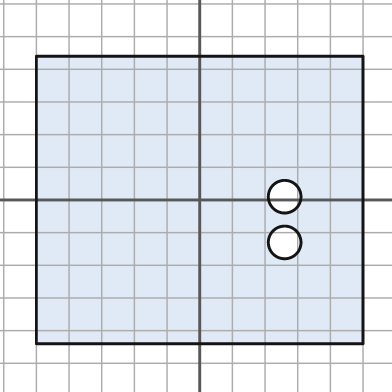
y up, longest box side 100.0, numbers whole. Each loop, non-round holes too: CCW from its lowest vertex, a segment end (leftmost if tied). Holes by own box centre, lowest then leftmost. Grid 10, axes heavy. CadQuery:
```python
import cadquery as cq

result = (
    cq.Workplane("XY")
    .moveTo(-50.0, -44.0)
    .lineTo(50.0, -44.0)
    .lineTo(50.0, 44.0)
    .lineTo(-50.0, 44.0)
    .close()
    .moveTo(26.0, -13.0)
    .circle(5.0)
    .moveTo(26.0, 1.0)
    .circle(5.0)
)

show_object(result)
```